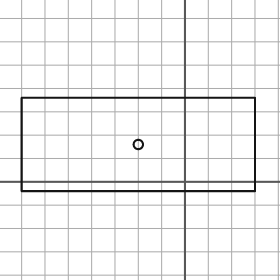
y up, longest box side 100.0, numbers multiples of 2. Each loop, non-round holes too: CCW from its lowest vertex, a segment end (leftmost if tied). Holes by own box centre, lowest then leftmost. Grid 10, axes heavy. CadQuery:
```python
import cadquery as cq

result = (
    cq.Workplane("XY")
    .moveTo(-70.0, -4.0)
    .lineTo(30.0, -4.0)
    .lineTo(30.0, 36.0)
    .lineTo(-70.0, 36.0)
    .close()
    .moveTo(-20.0, 16.0)
    .circle(2.0)
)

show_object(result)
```